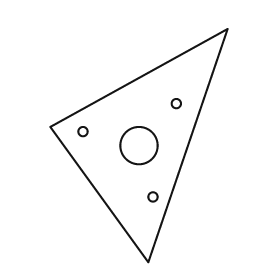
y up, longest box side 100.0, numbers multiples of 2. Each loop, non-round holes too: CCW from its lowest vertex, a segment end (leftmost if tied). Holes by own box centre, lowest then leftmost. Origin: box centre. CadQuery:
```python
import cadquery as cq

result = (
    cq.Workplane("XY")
    .moveTo(4.0, -50.0)
    .lineTo(38.0, 50.0)
    .lineTo(-38.0, 8.0)
    .close()
    .moveTo(6.0, -22.0)
    .circle(2.0)
    .moveTo(0.0, 0.0)
    .circle(8.0)
    .moveTo(-24.0, 6.0)
    .circle(2.0)
    .moveTo(16.0, 18.0)
    .circle(2.0)
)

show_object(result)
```